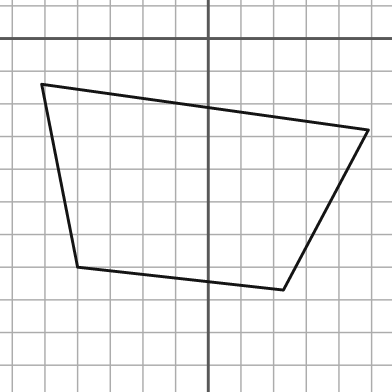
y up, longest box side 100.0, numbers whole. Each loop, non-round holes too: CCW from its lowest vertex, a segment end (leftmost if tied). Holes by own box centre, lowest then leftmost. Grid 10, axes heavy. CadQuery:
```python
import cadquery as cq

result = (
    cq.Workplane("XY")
    .moveTo(23.0, -77.0)
    .lineTo(49.0, -28.0)
    .lineTo(-51.0, -14.0)
    .lineTo(-40.0, -70.0)
    .close()
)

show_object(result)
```